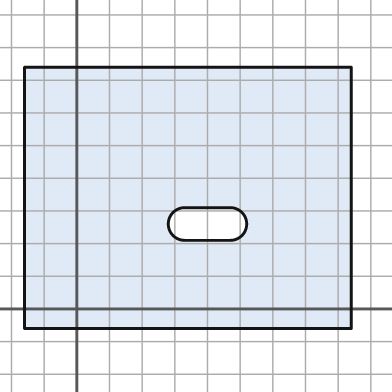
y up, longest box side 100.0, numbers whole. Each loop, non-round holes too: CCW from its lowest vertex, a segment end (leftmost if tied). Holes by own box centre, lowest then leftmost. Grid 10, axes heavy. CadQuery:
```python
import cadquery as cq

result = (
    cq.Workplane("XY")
    .moveTo(-16.0, -6.0)
    .lineTo(84.0, -6.0)
    .lineTo(84.0, 74.0)
    .lineTo(-16.0, 74.0)
    .close()
    .moveTo(33.0, 21.0)
    .lineTo(47.0, 21.0)
    .threePointArc((52.0, 26.0), (47.0, 31.0))
    .lineTo(33.0, 31.0)
    .threePointArc((28.0, 26.0), (33.0, 21.0))
    .close()
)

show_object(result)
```